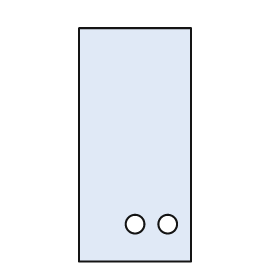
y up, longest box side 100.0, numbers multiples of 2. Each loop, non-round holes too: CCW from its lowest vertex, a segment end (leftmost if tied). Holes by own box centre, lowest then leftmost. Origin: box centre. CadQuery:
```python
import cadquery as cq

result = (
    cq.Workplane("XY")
    .moveTo(-24.0, -50.0)
    .lineTo(24.0, -50.0)
    .lineTo(24.0, 50.0)
    .lineTo(-24.0, 50.0)
    .close()
    .moveTo(0.0, -34.0)
    .circle(4.0)
    .moveTo(14.0, -34.0)
    .circle(4.0)
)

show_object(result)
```